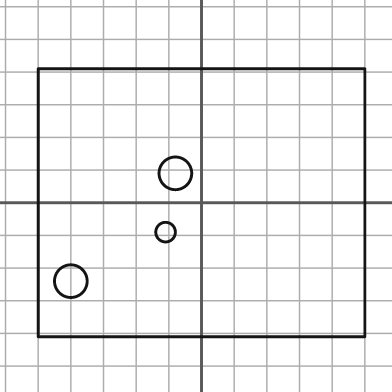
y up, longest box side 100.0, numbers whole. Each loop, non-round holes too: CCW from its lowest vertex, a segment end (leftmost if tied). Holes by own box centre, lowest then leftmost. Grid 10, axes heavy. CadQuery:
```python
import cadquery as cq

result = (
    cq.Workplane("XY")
    .moveTo(-50.0, -41.0)
    .lineTo(50.0, -41.0)
    .lineTo(50.0, 41.0)
    .lineTo(-50.0, 41.0)
    .close()
    .moveTo(-40.0, -24.0)
    .circle(5.0)
    .moveTo(-11.0, -9.0)
    .circle(3.0)
    .moveTo(-8.0, 9.0)
    .circle(5.0)
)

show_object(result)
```